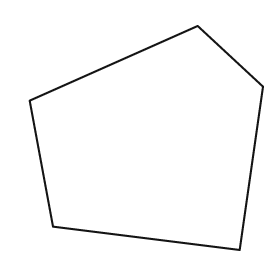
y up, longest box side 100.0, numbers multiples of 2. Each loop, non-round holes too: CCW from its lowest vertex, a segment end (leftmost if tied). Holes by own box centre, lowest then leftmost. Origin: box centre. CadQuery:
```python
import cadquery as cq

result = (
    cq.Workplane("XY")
    .moveTo(40.0, -48.0)
    .lineTo(50.0, 22.0)
    .lineTo(22.0, 48.0)
    .lineTo(-50.0, 16.0)
    .lineTo(-40.0, -38.0)
    .close()
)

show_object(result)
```